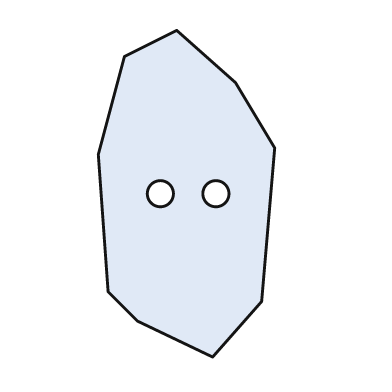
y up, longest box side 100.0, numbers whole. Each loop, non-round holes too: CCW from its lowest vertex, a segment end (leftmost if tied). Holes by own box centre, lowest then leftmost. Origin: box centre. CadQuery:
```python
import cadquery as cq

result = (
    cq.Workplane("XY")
    .moveTo(8.0, -50.0)
    .lineTo(23.0, -33.0)
    .lineTo(27.0, 14.0)
    .lineTo(15.0, 34.0)
    .lineTo(-3.0, 50.0)
    .lineTo(-19.0, 42.0)
    .lineTo(-27.0, 12.0)
    .lineTo(-24.0, -30.0)
    .lineTo(-15.0, -39.0)
    .close()
    .moveTo(-8.0, 0.0)
    .circle(4.0)
    .moveTo(9.0, 0.0)
    .circle(4.0)
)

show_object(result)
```